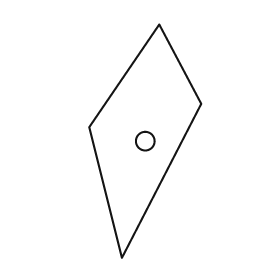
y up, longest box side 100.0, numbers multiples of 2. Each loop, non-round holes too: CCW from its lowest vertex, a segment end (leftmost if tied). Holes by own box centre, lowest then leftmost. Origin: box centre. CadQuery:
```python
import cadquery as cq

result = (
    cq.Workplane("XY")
    .moveTo(-10.0, -50.0)
    .lineTo(24.0, 16.0)
    .lineTo(6.0, 50.0)
    .lineTo(-24.0, 6.0)
    .close()
    .moveTo(0.0, 0.0)
    .circle(4.0)
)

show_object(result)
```